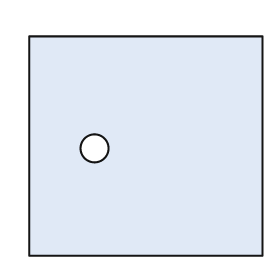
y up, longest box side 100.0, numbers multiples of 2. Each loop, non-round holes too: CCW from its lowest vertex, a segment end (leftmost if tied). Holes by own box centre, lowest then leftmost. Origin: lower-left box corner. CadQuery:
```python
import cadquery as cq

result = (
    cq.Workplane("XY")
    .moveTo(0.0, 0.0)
    .lineTo(100.0, 0.0)
    .lineTo(100.0, 94.0)
    .lineTo(0.0, 94.0)
    .close()
    .moveTo(28.0, 46.0)
    .circle(6.0)
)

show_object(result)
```